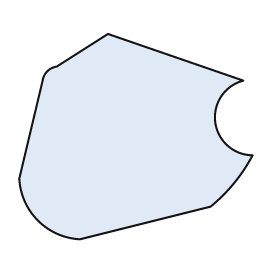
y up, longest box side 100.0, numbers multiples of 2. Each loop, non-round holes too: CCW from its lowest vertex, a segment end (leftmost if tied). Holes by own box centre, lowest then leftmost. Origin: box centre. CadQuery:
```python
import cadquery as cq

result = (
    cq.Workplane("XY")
    .moveTo(-24.0, -44.0)
    .lineTo(32.0, -30.0)
    .threePointArc((42.0, -20.0), (50.0, -8.0))
    .threePointArc((34.0, 6.0), (46.0, 24.0))
    .lineTo(-12.0, 44.0)
    .lineTo(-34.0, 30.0)
    .threePointArc((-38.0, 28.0), (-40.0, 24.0))
    .lineTo(-50.0, -18.0)
    .threePointArc((-42.0, -36.0), (-24.0, -44.0))
    .close()
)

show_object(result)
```